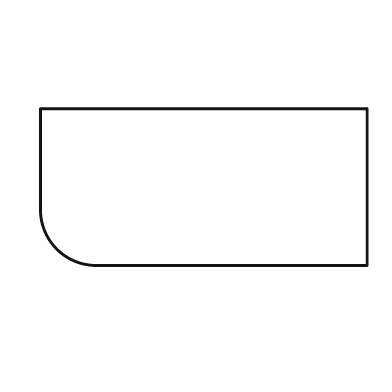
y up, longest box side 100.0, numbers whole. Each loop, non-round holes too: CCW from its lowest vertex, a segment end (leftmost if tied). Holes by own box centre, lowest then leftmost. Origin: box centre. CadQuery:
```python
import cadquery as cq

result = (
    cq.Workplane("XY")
    .moveTo(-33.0, -24.0)
    .lineTo(50.0, -24.0)
    .lineTo(50.0, 24.0)
    .lineTo(-50.0, 24.0)
    .lineTo(-50.0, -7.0)
    .threePointArc((-45.0, -19.0), (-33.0, -24.0))
    .close()
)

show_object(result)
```